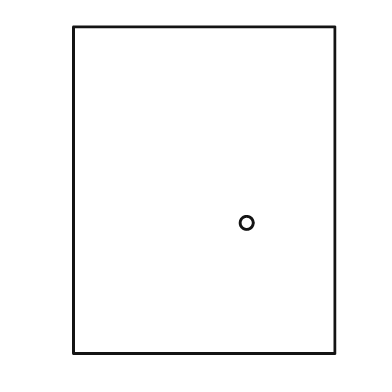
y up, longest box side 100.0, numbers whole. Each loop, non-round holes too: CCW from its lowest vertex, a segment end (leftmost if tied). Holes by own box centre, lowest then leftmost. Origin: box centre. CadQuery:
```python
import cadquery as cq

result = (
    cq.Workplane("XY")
    .moveTo(-40.0, -50.0)
    .lineTo(40.0, -50.0)
    .lineTo(40.0, 50.0)
    .lineTo(-40.0, 50.0)
    .close()
    .moveTo(13.0, -10.0)
    .circle(2.0)
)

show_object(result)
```